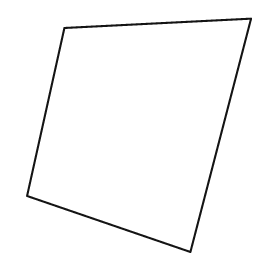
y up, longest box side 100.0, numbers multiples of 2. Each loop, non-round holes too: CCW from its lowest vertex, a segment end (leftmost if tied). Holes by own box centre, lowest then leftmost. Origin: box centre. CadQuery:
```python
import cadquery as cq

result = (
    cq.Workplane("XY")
    .moveTo(22.0, -50.0)
    .lineTo(48.0, 50.0)
    .lineTo(-32.0, 46.0)
    .lineTo(-48.0, -26.0)
    .close()
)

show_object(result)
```